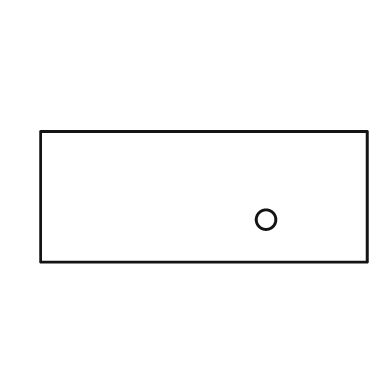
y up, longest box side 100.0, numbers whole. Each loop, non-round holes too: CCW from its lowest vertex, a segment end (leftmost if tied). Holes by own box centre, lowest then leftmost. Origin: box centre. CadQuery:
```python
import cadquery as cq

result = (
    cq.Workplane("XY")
    .moveTo(-50.0, -20.0)
    .lineTo(50.0, -20.0)
    .lineTo(50.0, 20.0)
    .lineTo(-50.0, 20.0)
    .close()
    .moveTo(19.0, -7.0)
    .circle(3.0)
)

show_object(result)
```